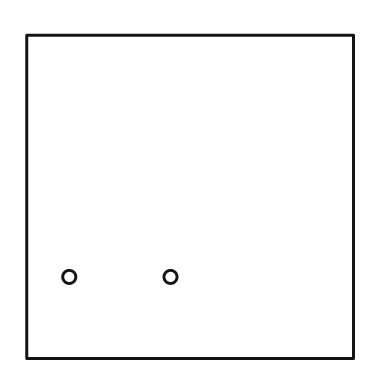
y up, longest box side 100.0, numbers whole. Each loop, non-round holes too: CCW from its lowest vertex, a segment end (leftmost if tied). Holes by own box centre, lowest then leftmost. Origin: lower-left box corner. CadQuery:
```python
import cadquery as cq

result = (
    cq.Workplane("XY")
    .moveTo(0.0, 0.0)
    .lineTo(100.0, 0.0)
    .lineTo(100.0, 99.0)
    .lineTo(0.0, 99.0)
    .close()
    .moveTo(13.0, 25.0)
    .circle(2.0)
    .moveTo(44.0, 25.0)
    .circle(2.0)
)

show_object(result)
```